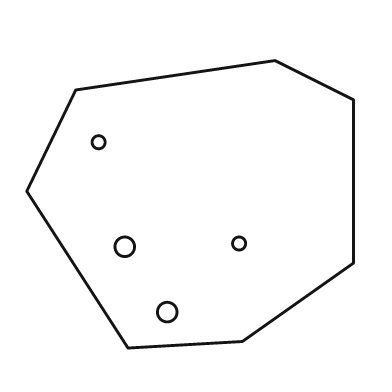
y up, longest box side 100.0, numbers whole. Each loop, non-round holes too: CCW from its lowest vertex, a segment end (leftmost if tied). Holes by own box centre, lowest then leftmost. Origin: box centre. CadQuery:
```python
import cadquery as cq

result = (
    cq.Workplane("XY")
    .moveTo(-19.0, -44.0)
    .lineTo(16.0, -42.0)
    .lineTo(50.0, -18.0)
    .lineTo(50.0, 32.0)
    .lineTo(26.0, 44.0)
    .lineTo(-35.0, 35.0)
    .lineTo(-50.0, 4.0)
    .close()
    .moveTo(-7.0, -33.0)
    .circle(3.0)
    .moveTo(-20.0, -13.0)
    .circle(3.0)
    .moveTo(15.0, -12.0)
    .circle(2.0)
    .moveTo(-28.0, 19.0)
    .circle(2.0)
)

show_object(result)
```